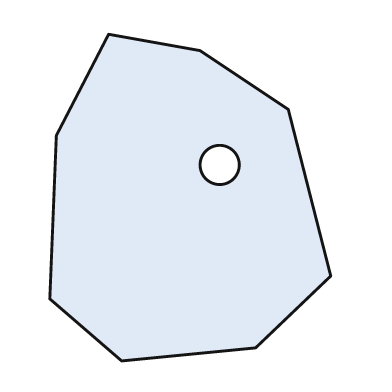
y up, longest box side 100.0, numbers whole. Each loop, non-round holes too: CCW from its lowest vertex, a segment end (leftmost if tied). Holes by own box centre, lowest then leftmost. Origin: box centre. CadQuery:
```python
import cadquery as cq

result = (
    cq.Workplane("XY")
    .moveTo(-21.0, -50.0)
    .lineTo(20.0, -46.0)
    .lineTo(43.0, -24.0)
    .lineTo(30.0, 27.0)
    .lineTo(3.0, 45.0)
    .lineTo(-25.0, 50.0)
    .lineTo(-41.0, 19.0)
    .lineTo(-43.0, -31.0)
    .close()
    .moveTo(9.0, 10.0)
    .circle(6.0)
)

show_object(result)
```